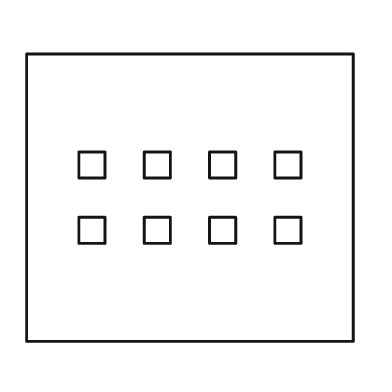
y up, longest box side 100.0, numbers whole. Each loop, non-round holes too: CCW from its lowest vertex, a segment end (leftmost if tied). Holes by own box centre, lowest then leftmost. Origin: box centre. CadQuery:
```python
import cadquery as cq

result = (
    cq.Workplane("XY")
    .moveTo(-50.0, -44.0)
    .lineTo(50.0, -44.0)
    .lineTo(50.0, 44.0)
    .lineTo(-50.0, 44.0)
    .close()
    .moveTo(-34.0, -14.0)
    .lineTo(-26.0, -14.0)
    .lineTo(-26.0, -6.0)
    .lineTo(-34.0, -6.0)
    .close()
    .moveTo(-14.0, -14.0)
    .lineTo(-6.0, -14.0)
    .lineTo(-6.0, -6.0)
    .lineTo(-14.0, -6.0)
    .close()
    .moveTo(6.0, -14.0)
    .lineTo(14.0, -14.0)
    .lineTo(14.0, -6.0)
    .lineTo(6.0, -6.0)
    .close()
    .moveTo(26.0, -14.0)
    .lineTo(34.0, -14.0)
    .lineTo(34.0, -6.0)
    .lineTo(26.0, -6.0)
    .close()
    .moveTo(-34.0, 6.0)
    .lineTo(-26.0, 6.0)
    .lineTo(-26.0, 14.0)
    .lineTo(-34.0, 14.0)
    .close()
    .moveTo(-14.0, 6.0)
    .lineTo(-6.0, 6.0)
    .lineTo(-6.0, 14.0)
    .lineTo(-14.0, 14.0)
    .close()
    .moveTo(6.0, 6.0)
    .lineTo(14.0, 6.0)
    .lineTo(14.0, 14.0)
    .lineTo(6.0, 14.0)
    .close()
    .moveTo(26.0, 6.0)
    .lineTo(34.0, 6.0)
    .lineTo(34.0, 14.0)
    .lineTo(26.0, 14.0)
    .close()
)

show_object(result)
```